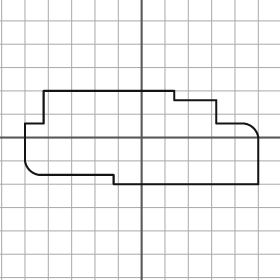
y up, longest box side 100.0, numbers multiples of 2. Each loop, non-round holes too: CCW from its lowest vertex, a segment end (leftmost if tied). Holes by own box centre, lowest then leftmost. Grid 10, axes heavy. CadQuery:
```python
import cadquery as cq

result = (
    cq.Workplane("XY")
    .moveTo(-12.0, -20.0)
    .lineTo(50.0, -20.0)
    .lineTo(50.0, 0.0)
    .threePointArc((48.0, 4.0), (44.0, 6.0))
    .lineTo(32.0, 6.0)
    .lineTo(32.0, 16.0)
    .lineTo(14.0, 16.0)
    .lineTo(14.0, 20.0)
    .lineTo(-42.0, 20.0)
    .lineTo(-42.0, 6.0)
    .lineTo(-50.0, 6.0)
    .lineTo(-50.0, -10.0)
    .threePointArc((-48.0, -14.0), (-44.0, -16.0))
    .lineTo(-12.0, -16.0)
    .close()
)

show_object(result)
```